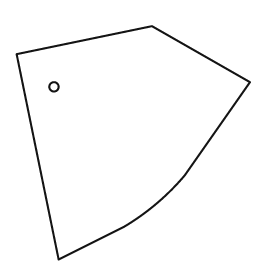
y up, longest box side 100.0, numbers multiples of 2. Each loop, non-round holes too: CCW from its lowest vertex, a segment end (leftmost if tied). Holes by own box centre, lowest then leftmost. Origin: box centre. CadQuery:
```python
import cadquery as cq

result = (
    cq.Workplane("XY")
    .moveTo(-32.0, -50.0)
    .lineTo(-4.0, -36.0)
    .threePointArc((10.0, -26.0), (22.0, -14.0))
    .lineTo(50.0, 26.0)
    .lineTo(8.0, 50.0)
    .lineTo(-50.0, 38.0)
    .close()
    .moveTo(-34.0, 24.0)
    .circle(2.0)
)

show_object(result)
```